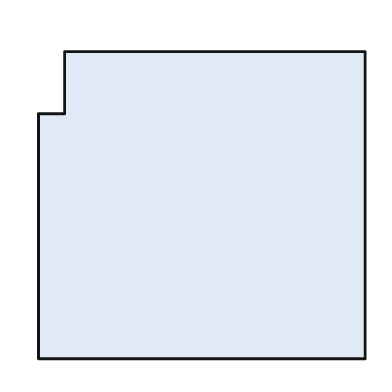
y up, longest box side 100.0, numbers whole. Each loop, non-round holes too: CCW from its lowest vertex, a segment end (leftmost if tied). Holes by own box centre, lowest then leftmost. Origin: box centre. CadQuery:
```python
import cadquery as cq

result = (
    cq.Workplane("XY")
    .moveTo(-50.0, -47.0)
    .lineTo(50.0, -47.0)
    .lineTo(50.0, 47.0)
    .lineTo(-42.0, 47.0)
    .lineTo(-42.0, 28.0)
    .lineTo(-50.0, 28.0)
    .close()
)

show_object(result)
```